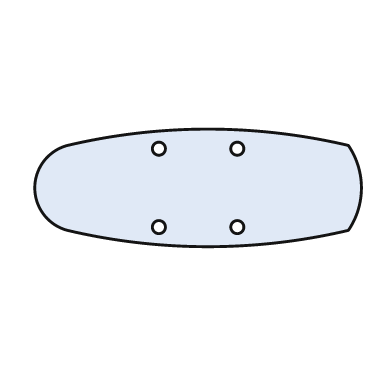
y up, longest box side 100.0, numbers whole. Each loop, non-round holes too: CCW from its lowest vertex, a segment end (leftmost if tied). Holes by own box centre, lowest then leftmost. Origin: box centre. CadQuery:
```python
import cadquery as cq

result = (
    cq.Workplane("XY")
    .moveTo(-40.0, -13.0)
    .threePointArc((3.0, -18.0), (46.0, -13.0))
    .threePointArc((50.0, 0.0), (46.0, 13.0))
    .threePointArc((3.0, 18.0), (-40.0, 13.0))
    .threePointArc((-50.0, 0.0), (-40.0, -13.0))
    .close()
    .moveTo(-12.0, -12.0)
    .circle(2.0)
    .moveTo(12.0, -12.0)
    .circle(2.0)
    .moveTo(-12.0, 12.0)
    .circle(2.0)
    .moveTo(12.0, 12.0)
    .circle(2.0)
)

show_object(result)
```